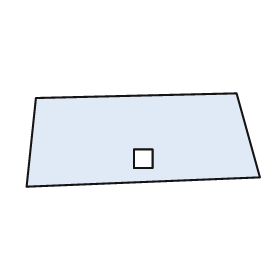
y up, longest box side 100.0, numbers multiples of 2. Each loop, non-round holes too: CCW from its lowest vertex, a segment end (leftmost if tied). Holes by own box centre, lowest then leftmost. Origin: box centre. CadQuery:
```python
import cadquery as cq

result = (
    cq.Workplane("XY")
    .moveTo(-50.0, -20.0)
    .lineTo(50.0, -16.0)
    .lineTo(40.0, 20.0)
    .lineTo(-46.0, 18.0)
    .close()
    .moveTo(-4.0, -12.0)
    .lineTo(4.0, -12.0)
    .lineTo(4.0, -4.0)
    .lineTo(-4.0, -4.0)
    .close()
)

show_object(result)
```